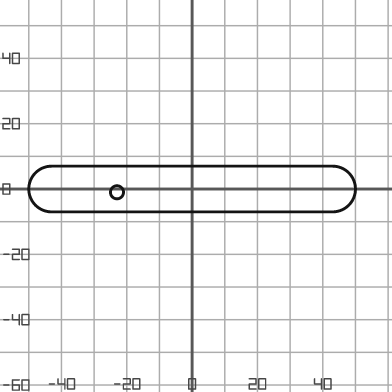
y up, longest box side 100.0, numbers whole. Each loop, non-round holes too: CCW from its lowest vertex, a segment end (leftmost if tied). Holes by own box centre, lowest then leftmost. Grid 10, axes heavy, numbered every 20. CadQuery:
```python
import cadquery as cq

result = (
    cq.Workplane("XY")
    .moveTo(-43.0, -7.0)
    .lineTo(43.0, -7.0)
    .threePointArc((50.0, 0.0), (43.0, 7.0))
    .lineTo(-43.0, 7.0)
    .threePointArc((-50.0, 0.0), (-43.0, -7.0))
    .close()
    .moveTo(-23.0, -1.0)
    .circle(2.0)
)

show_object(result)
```